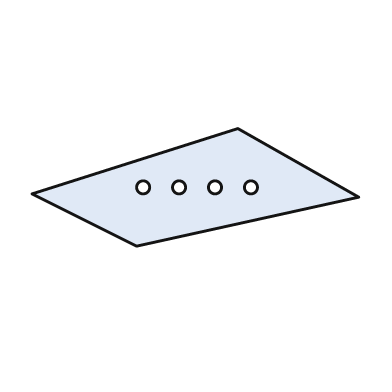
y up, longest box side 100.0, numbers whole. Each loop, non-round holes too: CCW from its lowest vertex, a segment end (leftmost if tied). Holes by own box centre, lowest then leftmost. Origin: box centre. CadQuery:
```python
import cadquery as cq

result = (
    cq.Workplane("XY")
    .moveTo(-18.0, -18.0)
    .lineTo(50.0, -3.0)
    .lineTo(13.0, 18.0)
    .lineTo(-50.0, -2.0)
    .close()
    .moveTo(-16.0, 0.0)
    .circle(2.0)
    .moveTo(-5.0, 0.0)
    .circle(2.0)
    .moveTo(6.0, 0.0)
    .circle(2.0)
    .moveTo(17.0, 0.0)
    .circle(2.0)
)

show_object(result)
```